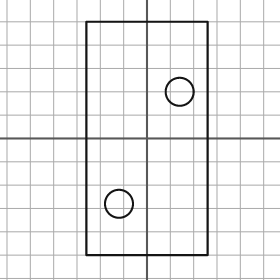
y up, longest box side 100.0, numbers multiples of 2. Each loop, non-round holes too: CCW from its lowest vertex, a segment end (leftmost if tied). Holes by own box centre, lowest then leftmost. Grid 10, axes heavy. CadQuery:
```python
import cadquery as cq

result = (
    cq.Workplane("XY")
    .moveTo(-26.0, -50.0)
    .lineTo(26.0, -50.0)
    .lineTo(26.0, 50.0)
    .lineTo(-26.0, 50.0)
    .close()
    .moveTo(-12.0, -28.0)
    .circle(6.0)
    .moveTo(14.0, 20.0)
    .circle(6.0)
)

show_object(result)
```